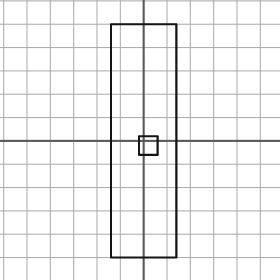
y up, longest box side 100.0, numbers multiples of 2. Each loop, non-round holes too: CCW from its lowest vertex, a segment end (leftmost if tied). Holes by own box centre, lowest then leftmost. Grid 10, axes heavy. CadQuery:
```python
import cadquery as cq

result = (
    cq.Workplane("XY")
    .moveTo(-14.0, -50.0)
    .lineTo(14.0, -50.0)
    .lineTo(14.0, 50.0)
    .lineTo(-14.0, 50.0)
    .close()
    .moveTo(-2.0, -6.0)
    .lineTo(6.0, -6.0)
    .lineTo(6.0, 2.0)
    .lineTo(-2.0, 2.0)
    .close()
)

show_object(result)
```